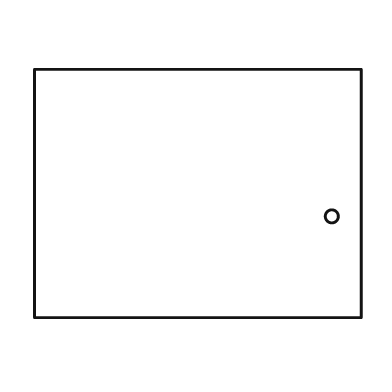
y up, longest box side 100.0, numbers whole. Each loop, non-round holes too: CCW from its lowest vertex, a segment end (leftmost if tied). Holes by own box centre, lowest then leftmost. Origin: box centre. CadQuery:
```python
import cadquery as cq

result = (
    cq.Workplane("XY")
    .moveTo(-50.0, -38.0)
    .lineTo(50.0, -38.0)
    .lineTo(50.0, 38.0)
    .lineTo(-50.0, 38.0)
    .close()
    .moveTo(41.0, -7.0)
    .circle(2.0)
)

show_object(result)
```